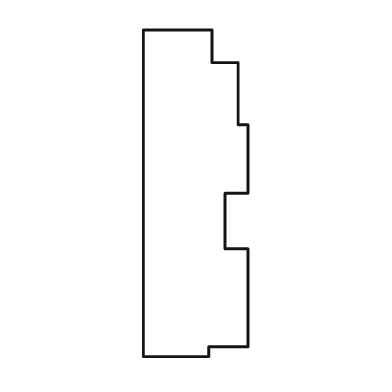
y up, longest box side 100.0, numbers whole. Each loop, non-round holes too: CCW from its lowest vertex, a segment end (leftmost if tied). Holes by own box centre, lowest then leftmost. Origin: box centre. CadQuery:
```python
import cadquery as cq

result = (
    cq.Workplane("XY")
    .moveTo(-16.0, -50.0)
    .lineTo(4.0, -50.0)
    .lineTo(4.0, -47.0)
    .lineTo(16.0, -47.0)
    .lineTo(16.0, -17.0)
    .lineTo(9.0, -17.0)
    .lineTo(9.0, 0.0)
    .lineTo(16.0, 0.0)
    .lineTo(16.0, 21.0)
    .lineTo(13.0, 21.0)
    .lineTo(13.0, 40.0)
    .lineTo(5.0, 40.0)
    .lineTo(5.0, 50.0)
    .lineTo(-16.0, 50.0)
    .close()
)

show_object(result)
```